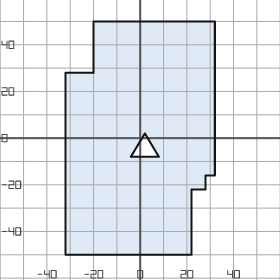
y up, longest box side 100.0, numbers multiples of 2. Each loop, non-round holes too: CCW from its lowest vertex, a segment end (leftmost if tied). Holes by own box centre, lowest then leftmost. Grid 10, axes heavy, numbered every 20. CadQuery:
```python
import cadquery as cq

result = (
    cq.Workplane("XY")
    .moveTo(-32.0, -50.0)
    .lineTo(22.0, -50.0)
    .lineTo(22.0, -22.0)
    .lineTo(28.0, -22.0)
    .lineTo(28.0, -16.0)
    .lineTo(32.0, -16.0)
    .lineTo(32.0, 50.0)
    .lineTo(-20.0, 50.0)
    .lineTo(-20.0, 28.0)
    .lineTo(-32.0, 28.0)
    .close()
    .moveTo(-4.0, -8.0)
    .lineTo(8.0, -8.0)
    .lineTo(2.0, 2.0)
    .close()
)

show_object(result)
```